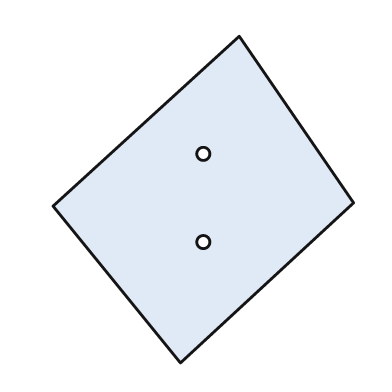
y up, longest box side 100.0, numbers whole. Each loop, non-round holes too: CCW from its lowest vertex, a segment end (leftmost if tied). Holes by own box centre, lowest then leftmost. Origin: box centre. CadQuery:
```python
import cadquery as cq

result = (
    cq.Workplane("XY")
    .moveTo(-7.0, -50.0)
    .lineTo(46.0, -1.0)
    .lineTo(11.0, 50.0)
    .lineTo(-46.0, -2.0)
    .close()
    .moveTo(0.0, -13.0)
    .circle(2.0)
    .moveTo(0.0, 14.0)
    .circle(2.0)
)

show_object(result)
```